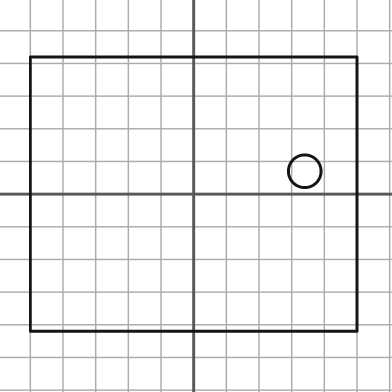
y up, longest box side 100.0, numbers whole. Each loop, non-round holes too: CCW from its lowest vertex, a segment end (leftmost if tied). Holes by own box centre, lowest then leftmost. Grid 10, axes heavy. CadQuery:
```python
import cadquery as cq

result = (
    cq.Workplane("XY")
    .moveTo(-50.0, -42.0)
    .lineTo(50.0, -42.0)
    .lineTo(50.0, 42.0)
    .lineTo(-50.0, 42.0)
    .close()
    .moveTo(34.0, 7.0)
    .circle(5.0)
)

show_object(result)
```